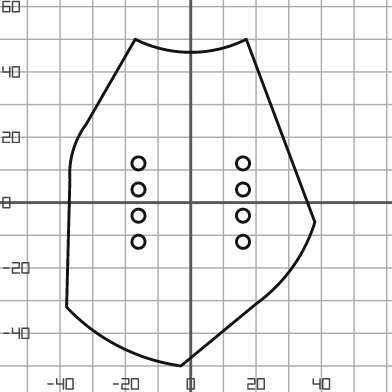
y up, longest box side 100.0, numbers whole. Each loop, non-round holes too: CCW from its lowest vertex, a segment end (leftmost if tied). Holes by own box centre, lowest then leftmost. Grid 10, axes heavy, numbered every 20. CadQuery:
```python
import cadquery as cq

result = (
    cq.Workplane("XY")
    .moveTo(-3.0, -50.0)
    .lineTo(20.0, -31.0)
    .threePointArc((31.0, -20.0), (38.0, -6.0))
    .lineTo(17.0, 50.0)
    .threePointArc((0.0, 46.0), (-17.0, 50.0))
    .lineTo(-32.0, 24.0)
    .threePointArc((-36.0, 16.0), (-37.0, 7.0))
    .lineTo(-38.0, -32.0)
    .threePointArc((-22.0, -44.0), (-3.0, -50.0))
    .close()
    .moveTo(-16.0, -12.0)
    .circle(2.0)
    .moveTo(16.0, -12.0)
    .circle(2.0)
    .moveTo(-16.0, -4.0)
    .circle(2.0)
    .moveTo(16.0, -4.0)
    .circle(2.0)
    .moveTo(-16.0, 4.0)
    .circle(2.0)
    .moveTo(16.0, 4.0)
    .circle(2.0)
    .moveTo(-16.0, 12.0)
    .circle(2.0)
    .moveTo(16.0, 12.0)
    .circle(2.0)
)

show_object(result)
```